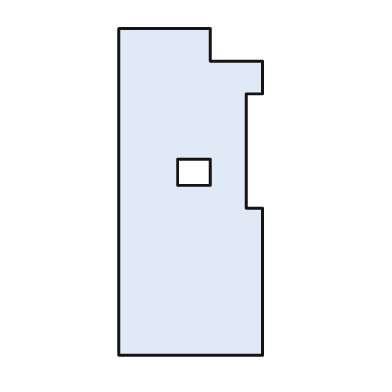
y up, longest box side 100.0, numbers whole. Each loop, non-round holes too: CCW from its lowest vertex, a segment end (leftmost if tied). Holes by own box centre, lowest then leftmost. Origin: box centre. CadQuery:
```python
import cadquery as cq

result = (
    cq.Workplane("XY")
    .moveTo(-22.0, -50.0)
    .lineTo(22.0, -50.0)
    .lineTo(22.0, -5.0)
    .lineTo(17.0, -5.0)
    .lineTo(17.0, 30.0)
    .lineTo(22.0, 30.0)
    .lineTo(22.0, 40.0)
    .lineTo(6.0, 40.0)
    .lineTo(6.0, 50.0)
    .lineTo(-22.0, 50.0)
    .close()
    .moveTo(-4.0, 2.0)
    .lineTo(6.0, 2.0)
    .lineTo(6.0, 10.0)
    .lineTo(-4.0, 10.0)
    .close()
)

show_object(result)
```